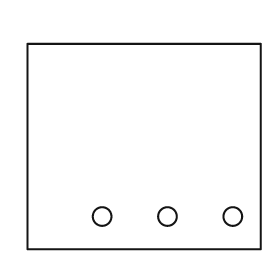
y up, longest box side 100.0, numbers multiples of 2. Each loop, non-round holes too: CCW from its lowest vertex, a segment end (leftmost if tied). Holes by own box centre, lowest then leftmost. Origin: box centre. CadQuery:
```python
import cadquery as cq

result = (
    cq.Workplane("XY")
    .moveTo(-50.0, -44.0)
    .lineTo(50.0, -44.0)
    .lineTo(50.0, 44.0)
    .lineTo(-50.0, 44.0)
    .close()
    .moveTo(-18.0, -30.0)
    .circle(4.0)
    .moveTo(10.0, -30.0)
    .circle(4.0)
    .moveTo(38.0, -30.0)
    .circle(4.0)
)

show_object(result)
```